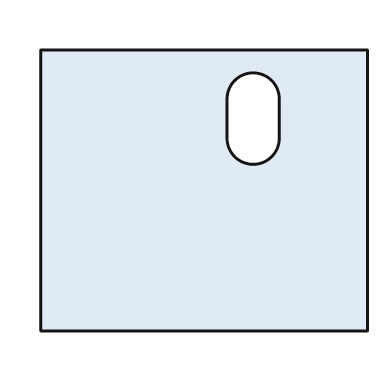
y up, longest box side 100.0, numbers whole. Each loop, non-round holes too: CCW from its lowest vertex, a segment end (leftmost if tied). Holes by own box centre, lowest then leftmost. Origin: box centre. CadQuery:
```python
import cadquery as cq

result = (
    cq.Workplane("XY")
    .moveTo(-50.0, -43.0)
    .lineTo(50.0, -43.0)
    .lineTo(50.0, 43.0)
    .lineTo(-50.0, 43.0)
    .close()
    .moveTo(7.0, 16.0)
    .threePointArc((15.0, 8.0), (23.0, 16.0))
    .lineTo(23.0, 28.0)
    .threePointArc((15.0, 36.0), (7.0, 28.0))
    .close()
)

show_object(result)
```